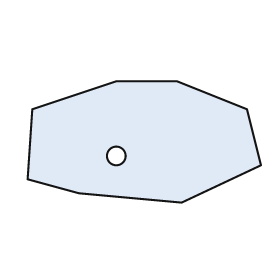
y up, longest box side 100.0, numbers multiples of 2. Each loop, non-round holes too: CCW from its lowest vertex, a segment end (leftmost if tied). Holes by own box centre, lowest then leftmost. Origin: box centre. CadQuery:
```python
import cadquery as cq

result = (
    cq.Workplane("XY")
    .moveTo(16.0, -26.0)
    .lineTo(50.0, -10.0)
    .lineTo(44.0, 14.0)
    .lineTo(14.0, 26.0)
    .lineTo(-12.0, 26.0)
    .lineTo(-48.0, 14.0)
    .lineTo(-50.0, -16.0)
    .lineTo(-28.0, -22.0)
    .close()
    .moveTo(-12.0, -6.0)
    .circle(4.0)
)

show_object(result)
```